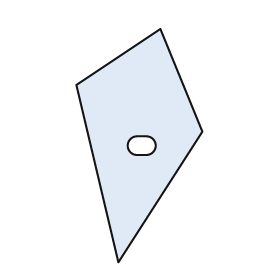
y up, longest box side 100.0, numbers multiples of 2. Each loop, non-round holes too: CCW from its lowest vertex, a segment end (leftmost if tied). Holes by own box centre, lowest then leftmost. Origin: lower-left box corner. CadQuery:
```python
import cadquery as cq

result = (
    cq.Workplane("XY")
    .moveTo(18.0, 0.0)
    .lineTo(54.0, 56.0)
    .lineTo(36.0, 100.0)
    .lineTo(0.0, 76.0)
    .close()
    .moveTo(26.0, 46.0)
    .lineTo(30.0, 46.0)
    .threePointArc((34.0, 50.0), (30.0, 54.0))
    .lineTo(26.0, 54.0)
    .threePointArc((22.0, 50.0), (26.0, 46.0))
    .close()
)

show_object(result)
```